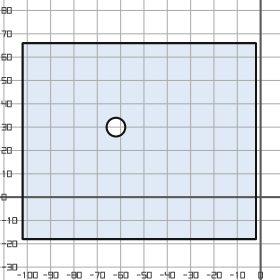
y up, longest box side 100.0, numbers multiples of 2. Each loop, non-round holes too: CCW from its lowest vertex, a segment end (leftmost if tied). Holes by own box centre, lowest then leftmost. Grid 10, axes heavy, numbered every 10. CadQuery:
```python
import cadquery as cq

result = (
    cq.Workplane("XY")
    .moveTo(-102.0, -18.0)
    .lineTo(-2.0, -18.0)
    .lineTo(-2.0, 66.0)
    .lineTo(-102.0, 66.0)
    .close()
    .moveTo(-62.0, 30.0)
    .circle(4.0)
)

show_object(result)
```